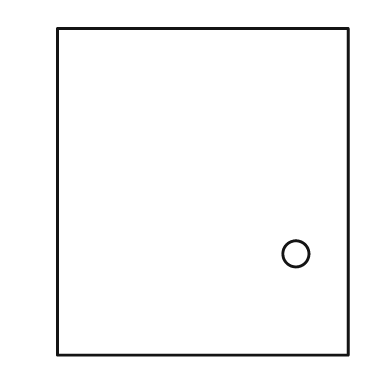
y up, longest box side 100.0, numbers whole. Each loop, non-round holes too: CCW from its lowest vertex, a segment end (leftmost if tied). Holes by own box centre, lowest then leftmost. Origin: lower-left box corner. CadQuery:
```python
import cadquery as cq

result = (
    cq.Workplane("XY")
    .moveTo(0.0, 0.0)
    .lineTo(89.0, 0.0)
    .lineTo(89.0, 100.0)
    .lineTo(0.0, 100.0)
    .close()
    .moveTo(73.0, 31.0)
    .circle(4.0)
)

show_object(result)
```